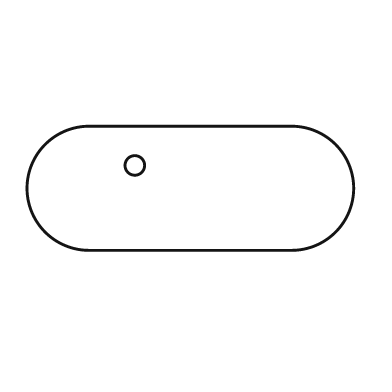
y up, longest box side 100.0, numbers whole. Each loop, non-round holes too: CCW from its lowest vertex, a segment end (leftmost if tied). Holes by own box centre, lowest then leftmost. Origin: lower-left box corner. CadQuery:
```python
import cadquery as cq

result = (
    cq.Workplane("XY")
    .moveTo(19.0, 0.0)
    .lineTo(81.0, 0.0)
    .threePointArc((100.0, 19.0), (81.0, 38.0))
    .lineTo(19.0, 38.0)
    .threePointArc((0.0, 19.0), (19.0, 0.0))
    .close()
    .moveTo(33.0, 26.0)
    .circle(3.0)
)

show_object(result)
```